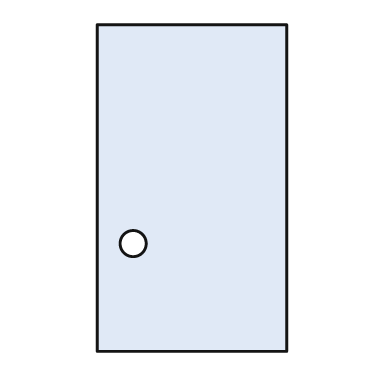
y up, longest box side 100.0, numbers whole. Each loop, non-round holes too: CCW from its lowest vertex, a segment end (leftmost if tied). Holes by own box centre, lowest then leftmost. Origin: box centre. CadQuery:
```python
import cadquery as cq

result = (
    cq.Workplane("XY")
    .moveTo(-29.0, -50.0)
    .lineTo(29.0, -50.0)
    .lineTo(29.0, 50.0)
    .lineTo(-29.0, 50.0)
    .close()
    .moveTo(-18.0, -17.0)
    .circle(4.0)
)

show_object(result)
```